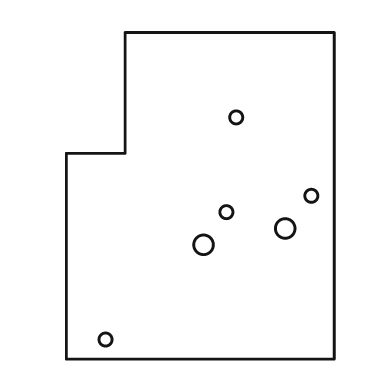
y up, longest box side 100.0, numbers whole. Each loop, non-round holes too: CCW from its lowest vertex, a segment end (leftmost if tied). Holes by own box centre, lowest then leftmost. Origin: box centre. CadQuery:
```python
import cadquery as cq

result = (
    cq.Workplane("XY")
    .moveTo(-41.0, -50.0)
    .lineTo(41.0, -50.0)
    .lineTo(41.0, 50.0)
    .lineTo(-23.0, 50.0)
    .lineTo(-23.0, 13.0)
    .lineTo(-41.0, 13.0)
    .close()
    .moveTo(-29.0, -44.0)
    .circle(2.0)
    .moveTo(1.0, -15.0)
    .circle(3.0)
    .moveTo(26.0, -10.0)
    .circle(3.0)
    .moveTo(8.0, -5.0)
    .circle(2.0)
    .moveTo(34.0, 0.0)
    .circle(2.0)
    .moveTo(11.0, 24.0)
    .circle(2.0)
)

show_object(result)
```